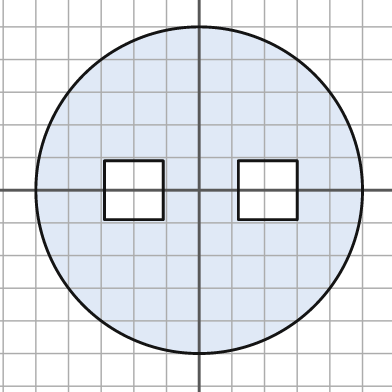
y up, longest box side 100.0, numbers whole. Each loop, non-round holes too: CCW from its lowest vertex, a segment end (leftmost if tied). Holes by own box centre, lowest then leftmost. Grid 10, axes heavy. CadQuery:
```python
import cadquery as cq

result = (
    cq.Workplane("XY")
    .moveTo(0.0, 0.0)
    .circle(50.0)
    .moveTo(-29.0, -9.0)
    .lineTo(-11.0, -9.0)
    .lineTo(-11.0, 9.0)
    .lineTo(-29.0, 9.0)
    .close()
    .moveTo(12.0, -9.0)
    .lineTo(30.0, -9.0)
    .lineTo(30.0, 9.0)
    .lineTo(12.0, 9.0)
    .close()
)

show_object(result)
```